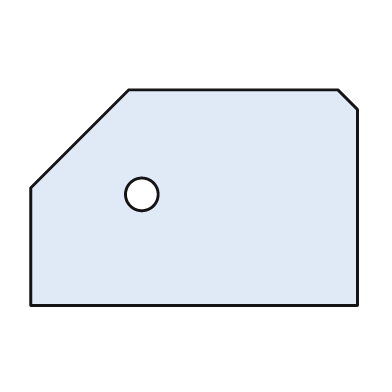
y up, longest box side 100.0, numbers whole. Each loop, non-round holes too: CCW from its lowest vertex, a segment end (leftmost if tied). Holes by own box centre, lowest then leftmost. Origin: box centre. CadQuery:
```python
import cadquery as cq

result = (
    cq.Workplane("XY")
    .moveTo(-50.0, -33.0)
    .lineTo(50.0, -33.0)
    .lineTo(50.0, 27.0)
    .lineTo(44.0, 33.0)
    .lineTo(-20.0, 33.0)
    .lineTo(-50.0, 3.0)
    .close()
    .moveTo(-16.0, 1.0)
    .circle(5.0)
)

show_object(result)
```